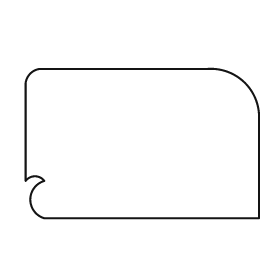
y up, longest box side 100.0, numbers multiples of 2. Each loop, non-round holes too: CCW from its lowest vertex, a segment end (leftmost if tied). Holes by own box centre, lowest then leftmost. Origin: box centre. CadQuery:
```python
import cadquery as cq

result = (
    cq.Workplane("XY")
    .moveTo(-42.0, -32.0)
    .lineTo(50.0, -32.0)
    .lineTo(50.0, 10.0)
    .threePointArc((44.0, 26.0), (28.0, 32.0))
    .lineTo(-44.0, 32.0)
    .threePointArc((-48.0, 30.0), (-50.0, 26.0))
    .lineTo(-50.0, -16.0)
    .threePointArc((-46.0, -14.0), (-42.0, -16.0))
    .threePointArc((-48.0, -24.0), (-42.0, -32.0))
    .close()
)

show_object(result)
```